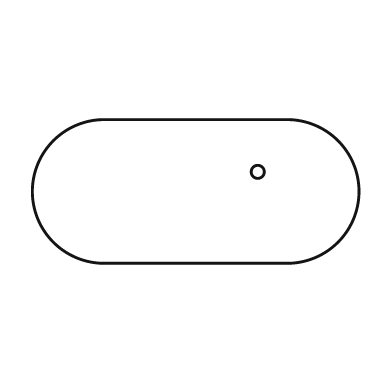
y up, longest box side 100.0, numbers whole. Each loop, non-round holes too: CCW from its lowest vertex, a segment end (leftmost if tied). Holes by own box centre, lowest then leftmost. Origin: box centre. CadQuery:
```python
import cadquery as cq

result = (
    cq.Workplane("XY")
    .moveTo(-28.0, -22.0)
    .lineTo(28.0, -22.0)
    .threePointArc((50.0, 0.0), (28.0, 22.0))
    .lineTo(-28.0, 22.0)
    .threePointArc((-50.0, 0.0), (-28.0, -22.0))
    .close()
    .moveTo(19.0, 6.0)
    .circle(2.0)
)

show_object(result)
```